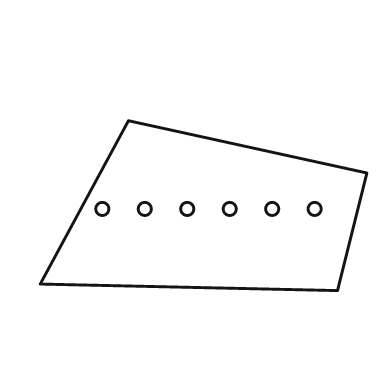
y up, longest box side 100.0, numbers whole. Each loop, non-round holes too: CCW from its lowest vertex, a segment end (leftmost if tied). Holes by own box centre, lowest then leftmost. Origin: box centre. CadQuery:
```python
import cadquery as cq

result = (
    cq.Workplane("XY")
    .moveTo(41.0, -26.0)
    .lineTo(50.0, 10.0)
    .lineTo(-23.0, 26.0)
    .lineTo(-50.0, -24.0)
    .close()
    .moveTo(-31.0, -1.0)
    .circle(2.0)
    .moveTo(-18.0, -1.0)
    .circle(2.0)
    .moveTo(-5.0, -1.0)
    .circle(2.0)
    .moveTo(8.0, -1.0)
    .circle(2.0)
    .moveTo(21.0, -1.0)
    .circle(2.0)
    .moveTo(34.0, -1.0)
    .circle(2.0)
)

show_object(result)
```